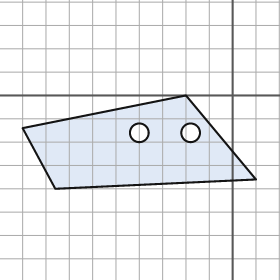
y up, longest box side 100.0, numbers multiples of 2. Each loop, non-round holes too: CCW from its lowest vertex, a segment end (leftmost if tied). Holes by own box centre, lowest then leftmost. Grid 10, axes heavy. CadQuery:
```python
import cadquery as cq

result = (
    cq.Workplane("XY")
    .moveTo(-76.0, -40.0)
    .lineTo(10.0, -36.0)
    .lineTo(-20.0, 0.0)
    .lineTo(-90.0, -14.0)
    .close()
    .moveTo(-40.0, -16.0)
    .circle(4.0)
    .moveTo(-18.0, -16.0)
    .circle(4.0)
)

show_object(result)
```